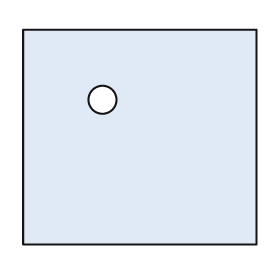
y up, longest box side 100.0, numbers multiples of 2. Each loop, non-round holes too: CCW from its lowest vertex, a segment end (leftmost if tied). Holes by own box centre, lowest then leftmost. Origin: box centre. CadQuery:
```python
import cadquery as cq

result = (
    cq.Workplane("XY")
    .moveTo(-50.0, -46.0)
    .lineTo(50.0, -46.0)
    .lineTo(50.0, 46.0)
    .lineTo(-50.0, 46.0)
    .close()
    .moveTo(-16.0, 16.0)
    .circle(6.0)
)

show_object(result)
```